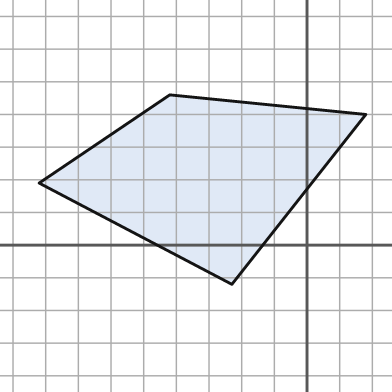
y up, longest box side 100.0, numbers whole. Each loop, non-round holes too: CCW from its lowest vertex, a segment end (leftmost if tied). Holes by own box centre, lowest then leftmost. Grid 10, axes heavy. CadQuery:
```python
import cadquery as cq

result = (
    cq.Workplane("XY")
    .moveTo(-23.0, -12.0)
    .lineTo(18.0, 40.0)
    .lineTo(-42.0, 46.0)
    .lineTo(-82.0, 19.0)
    .close()
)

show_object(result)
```